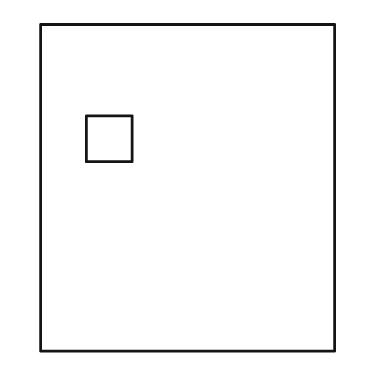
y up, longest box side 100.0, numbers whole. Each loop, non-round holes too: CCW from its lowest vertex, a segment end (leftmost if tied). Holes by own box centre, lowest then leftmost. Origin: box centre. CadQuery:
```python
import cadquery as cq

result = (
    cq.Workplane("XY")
    .moveTo(-45.0, -50.0)
    .lineTo(45.0, -50.0)
    .lineTo(45.0, 50.0)
    .lineTo(-45.0, 50.0)
    .close()
    .moveTo(-31.0, 8.0)
    .lineTo(-17.0, 8.0)
    .lineTo(-17.0, 22.0)
    .lineTo(-31.0, 22.0)
    .close()
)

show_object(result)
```